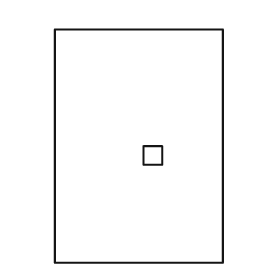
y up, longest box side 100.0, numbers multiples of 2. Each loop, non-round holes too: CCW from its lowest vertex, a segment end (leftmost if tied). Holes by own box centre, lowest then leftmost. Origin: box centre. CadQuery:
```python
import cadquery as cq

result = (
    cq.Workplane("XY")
    .moveTo(-36.0, -50.0)
    .lineTo(36.0, -50.0)
    .lineTo(36.0, 50.0)
    .lineTo(-36.0, 50.0)
    .close()
    .moveTo(2.0, -8.0)
    .lineTo(10.0, -8.0)
    .lineTo(10.0, 0.0)
    .lineTo(2.0, 0.0)
    .close()
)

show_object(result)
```